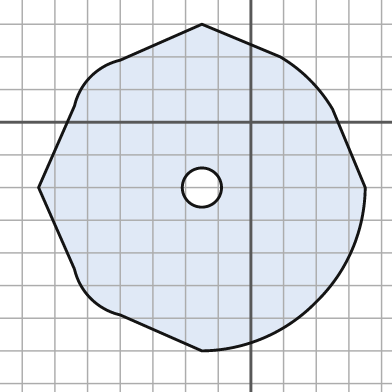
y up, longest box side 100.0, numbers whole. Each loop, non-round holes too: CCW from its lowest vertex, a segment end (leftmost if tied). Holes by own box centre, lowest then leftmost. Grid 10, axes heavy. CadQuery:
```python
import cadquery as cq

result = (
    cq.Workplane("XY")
    .moveTo(-15.0, -70.0)
    .threePointArc((4.0, -66.0), (20.0, -55.0))
    .threePointArc((31.0, -39.0), (35.0, -20.0))
    .lineTo(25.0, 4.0)
    .threePointArc((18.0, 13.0), (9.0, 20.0))
    .lineTo(-15.0, 30.0)
    .lineTo(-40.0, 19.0)
    .threePointArc((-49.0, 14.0), (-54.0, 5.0))
    .lineTo(-65.0, -20.0)
    .lineTo(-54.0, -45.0)
    .threePointArc((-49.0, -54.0), (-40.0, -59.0))
    .close()
    .moveTo(-15.0, -20.0)
    .circle(6.0)
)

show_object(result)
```